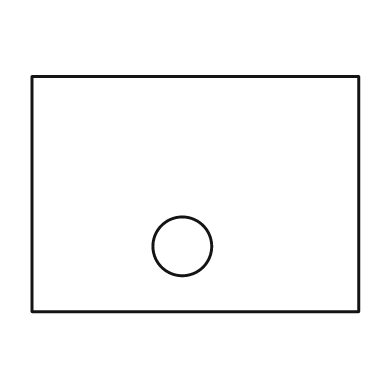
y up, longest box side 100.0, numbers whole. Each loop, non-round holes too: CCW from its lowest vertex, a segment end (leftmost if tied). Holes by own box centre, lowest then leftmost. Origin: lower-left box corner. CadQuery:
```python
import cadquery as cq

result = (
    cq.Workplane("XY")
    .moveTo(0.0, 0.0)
    .lineTo(100.0, 0.0)
    .lineTo(100.0, 72.0)
    .lineTo(0.0, 72.0)
    .close()
    .moveTo(46.0, 20.0)
    .circle(9.0)
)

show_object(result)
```